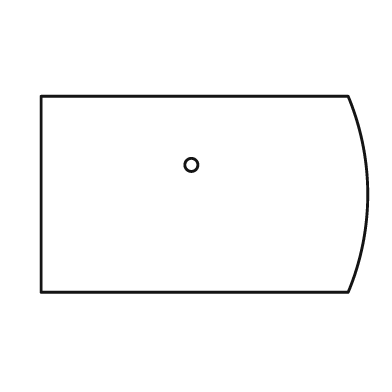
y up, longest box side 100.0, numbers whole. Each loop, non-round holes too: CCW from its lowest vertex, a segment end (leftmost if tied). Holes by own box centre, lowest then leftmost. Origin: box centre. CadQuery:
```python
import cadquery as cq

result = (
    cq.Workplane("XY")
    .moveTo(-50.0, -30.0)
    .lineTo(44.0, -30.0)
    .threePointArc((50.0, 0.0), (44.0, 30.0))
    .lineTo(-50.0, 30.0)
    .close()
    .moveTo(-4.0, 9.0)
    .circle(2.0)
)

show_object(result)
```